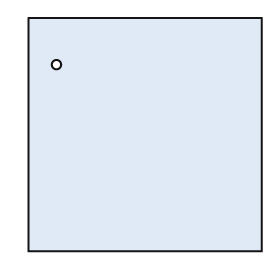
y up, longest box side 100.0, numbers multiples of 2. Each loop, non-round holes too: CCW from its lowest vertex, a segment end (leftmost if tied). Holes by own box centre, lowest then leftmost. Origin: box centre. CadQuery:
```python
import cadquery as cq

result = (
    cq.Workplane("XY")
    .moveTo(-50.0, -50.0)
    .lineTo(50.0, -50.0)
    .lineTo(50.0, 50.0)
    .lineTo(-50.0, 50.0)
    .close()
    .moveTo(-38.0, 30.0)
    .circle(2.0)
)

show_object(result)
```